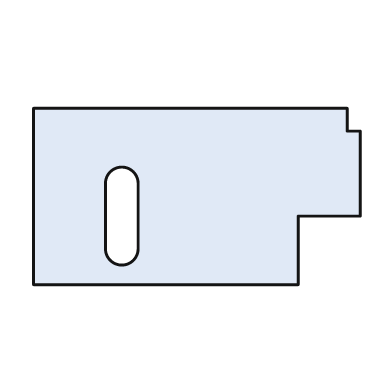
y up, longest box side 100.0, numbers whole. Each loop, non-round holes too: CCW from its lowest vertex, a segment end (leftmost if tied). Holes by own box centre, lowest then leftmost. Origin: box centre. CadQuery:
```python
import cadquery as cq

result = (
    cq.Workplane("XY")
    .moveTo(-50.0, -27.0)
    .lineTo(31.0, -27.0)
    .lineTo(31.0, -6.0)
    .lineTo(50.0, -6.0)
    .lineTo(50.0, 20.0)
    .lineTo(46.0, 20.0)
    .lineTo(46.0, 27.0)
    .lineTo(-50.0, 27.0)
    .close()
    .moveTo(-28.0, -16.0)
    .threePointArc((-23.0, -21.0), (-18.0, -16.0))
    .lineTo(-18.0, 4.0)
    .threePointArc((-23.0, 9.0), (-28.0, 4.0))
    .close()
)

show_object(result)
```